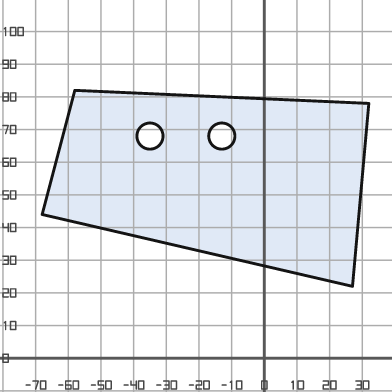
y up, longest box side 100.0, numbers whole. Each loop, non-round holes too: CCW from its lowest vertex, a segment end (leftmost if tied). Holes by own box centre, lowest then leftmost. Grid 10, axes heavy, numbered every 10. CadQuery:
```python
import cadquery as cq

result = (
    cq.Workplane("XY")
    .moveTo(27.0, 22.0)
    .lineTo(32.0, 78.0)
    .lineTo(-58.0, 82.0)
    .lineTo(-68.0, 44.0)
    .close()
    .moveTo(-35.0, 68.0)
    .circle(4.0)
    .moveTo(-13.0, 68.0)
    .circle(4.0)
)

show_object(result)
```